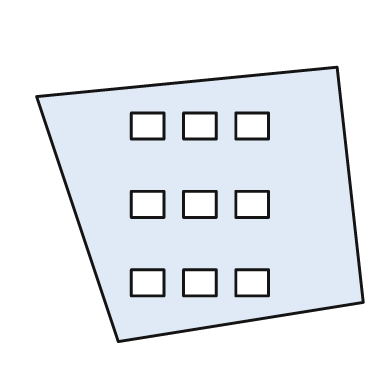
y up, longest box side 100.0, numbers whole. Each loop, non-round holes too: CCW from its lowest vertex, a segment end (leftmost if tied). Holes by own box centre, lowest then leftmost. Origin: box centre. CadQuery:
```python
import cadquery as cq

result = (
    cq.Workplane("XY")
    .moveTo(-25.0, -42.0)
    .lineTo(50.0, -30.0)
    .lineTo(42.0, 42.0)
    .lineTo(-50.0, 33.0)
    .close()
    .moveTo(-21.0, -28.0)
    .lineTo(-11.0, -28.0)
    .lineTo(-11.0, -20.0)
    .lineTo(-21.0, -20.0)
    .close()
    .moveTo(-5.0, -28.0)
    .lineTo(5.0, -28.0)
    .lineTo(5.0, -20.0)
    .lineTo(-5.0, -20.0)
    .close()
    .moveTo(11.0, -28.0)
    .lineTo(21.0, -28.0)
    .lineTo(21.0, -20.0)
    .lineTo(11.0, -20.0)
    .close()
    .moveTo(-21.0, -4.0)
    .lineTo(-11.0, -4.0)
    .lineTo(-11.0, 4.0)
    .lineTo(-21.0, 4.0)
    .close()
    .moveTo(-5.0, -4.0)
    .lineTo(5.0, -4.0)
    .lineTo(5.0, 4.0)
    .lineTo(-5.0, 4.0)
    .close()
    .moveTo(11.0, -4.0)
    .lineTo(21.0, -4.0)
    .lineTo(21.0, 4.0)
    .lineTo(11.0, 4.0)
    .close()
    .moveTo(-21.0, 20.0)
    .lineTo(-11.0, 20.0)
    .lineTo(-11.0, 28.0)
    .lineTo(-21.0, 28.0)
    .close()
    .moveTo(-5.0, 20.0)
    .lineTo(5.0, 20.0)
    .lineTo(5.0, 28.0)
    .lineTo(-5.0, 28.0)
    .close()
    .moveTo(11.0, 20.0)
    .lineTo(21.0, 20.0)
    .lineTo(21.0, 28.0)
    .lineTo(11.0, 28.0)
    .close()
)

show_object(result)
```